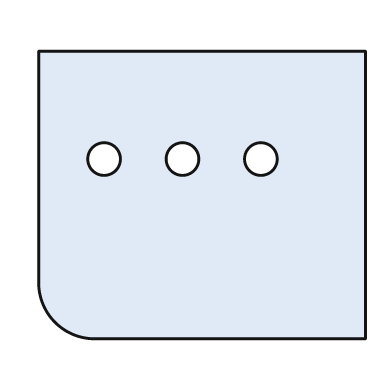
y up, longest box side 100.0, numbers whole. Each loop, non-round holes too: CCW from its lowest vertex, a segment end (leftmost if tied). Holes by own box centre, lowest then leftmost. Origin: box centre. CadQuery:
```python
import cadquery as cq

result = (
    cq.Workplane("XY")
    .moveTo(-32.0, -44.0)
    .lineTo(50.0, -44.0)
    .lineTo(50.0, 44.0)
    .lineTo(-50.0, 44.0)
    .lineTo(-50.0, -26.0)
    .threePointArc((-45.0, -39.0), (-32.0, -44.0))
    .close()
    .moveTo(-30.0, 11.0)
    .circle(5.0)
    .moveTo(-6.0, 11.0)
    .circle(5.0)
    .moveTo(18.0, 11.0)
    .circle(5.0)
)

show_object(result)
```